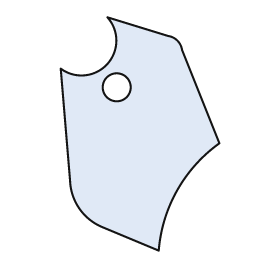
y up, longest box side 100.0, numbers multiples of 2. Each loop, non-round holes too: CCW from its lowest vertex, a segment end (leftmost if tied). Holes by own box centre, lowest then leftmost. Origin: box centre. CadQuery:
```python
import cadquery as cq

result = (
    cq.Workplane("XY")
    .moveTo(8.0, -50.0)
    .threePointArc((16.0, -24.0), (34.0, -4.0))
    .lineTo(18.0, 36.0)
    .threePointArc((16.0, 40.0), (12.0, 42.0))
    .lineTo(-14.0, 50.0)
    .threePointArc((-14.0, 30.0), (-34.0, 28.0))
    .lineTo(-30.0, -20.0)
    .threePointArc((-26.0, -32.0), (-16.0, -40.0))
    .close()
    .moveTo(-10.0, 20.0)
    .circle(6.0)
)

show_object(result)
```